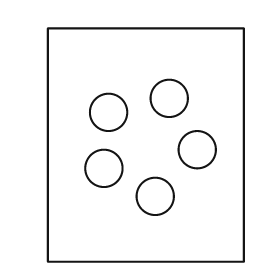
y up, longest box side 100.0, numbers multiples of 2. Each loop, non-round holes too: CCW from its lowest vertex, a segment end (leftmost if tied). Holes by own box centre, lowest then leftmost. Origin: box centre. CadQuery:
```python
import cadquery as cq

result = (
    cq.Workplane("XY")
    .moveTo(-42.0, -50.0)
    .lineTo(42.0, -50.0)
    .lineTo(42.0, 50.0)
    .lineTo(-42.0, 50.0)
    .close()
    .moveTo(4.0, -22.0)
    .circle(8.0)
    .moveTo(-18.0, -10.0)
    .circle(8.0)
    .moveTo(22.0, -2.0)
    .circle(8.0)
    .moveTo(-16.0, 14.0)
    .circle(8.0)
    .moveTo(10.0, 20.0)
    .circle(8.0)
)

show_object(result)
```